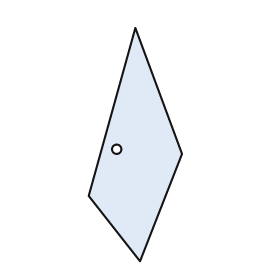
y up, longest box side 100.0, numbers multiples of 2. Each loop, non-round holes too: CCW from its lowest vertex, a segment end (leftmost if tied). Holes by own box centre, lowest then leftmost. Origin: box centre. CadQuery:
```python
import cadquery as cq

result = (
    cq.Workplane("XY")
    .moveTo(2.0, -50.0)
    .lineTo(20.0, -4.0)
    .lineTo(0.0, 50.0)
    .lineTo(-20.0, -22.0)
    .close()
    .moveTo(-8.0, -2.0)
    .circle(2.0)
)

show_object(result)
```